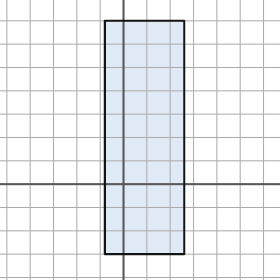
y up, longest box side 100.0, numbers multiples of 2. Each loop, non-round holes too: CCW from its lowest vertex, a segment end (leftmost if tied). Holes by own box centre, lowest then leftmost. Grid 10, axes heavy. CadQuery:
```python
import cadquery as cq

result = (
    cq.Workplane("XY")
    .moveTo(-8.0, -30.0)
    .lineTo(26.0, -30.0)
    .lineTo(26.0, 70.0)
    .lineTo(-8.0, 70.0)
    .close()
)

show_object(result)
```